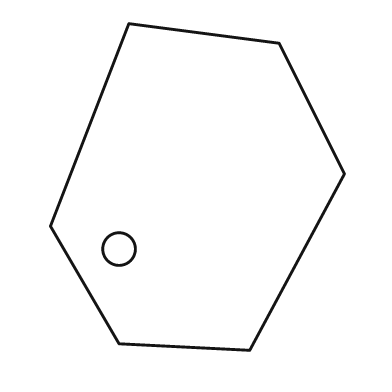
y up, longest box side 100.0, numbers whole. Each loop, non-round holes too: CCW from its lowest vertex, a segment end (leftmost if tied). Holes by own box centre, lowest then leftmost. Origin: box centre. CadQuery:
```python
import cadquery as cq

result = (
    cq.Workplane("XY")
    .moveTo(16.0, -50.0)
    .lineTo(45.0, 4.0)
    .lineTo(25.0, 44.0)
    .lineTo(-21.0, 50.0)
    .lineTo(-45.0, -12.0)
    .lineTo(-24.0, -48.0)
    .close()
    .moveTo(-24.0, -19.0)
    .circle(5.0)
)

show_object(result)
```